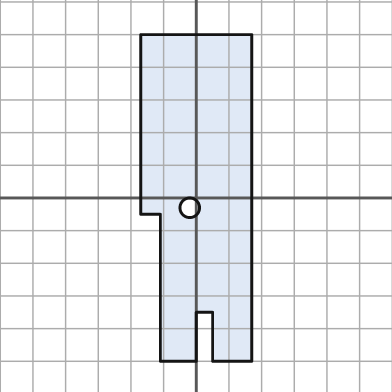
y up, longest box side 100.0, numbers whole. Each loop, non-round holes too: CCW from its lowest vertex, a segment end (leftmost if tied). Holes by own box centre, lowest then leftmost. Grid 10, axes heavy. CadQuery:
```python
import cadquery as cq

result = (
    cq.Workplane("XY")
    .moveTo(-11.0, -50.0)
    .lineTo(0.0, -50.0)
    .lineTo(0.0, -35.0)
    .lineTo(5.0, -35.0)
    .lineTo(5.0, -50.0)
    .lineTo(17.0, -50.0)
    .lineTo(17.0, 50.0)
    .lineTo(-17.0, 50.0)
    .lineTo(-17.0, -5.0)
    .lineTo(-11.0, -5.0)
    .close()
    .moveTo(-2.0, -3.0)
    .circle(3.0)
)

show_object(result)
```